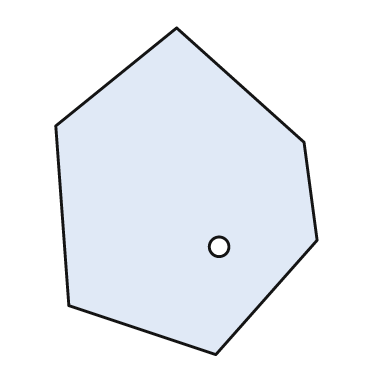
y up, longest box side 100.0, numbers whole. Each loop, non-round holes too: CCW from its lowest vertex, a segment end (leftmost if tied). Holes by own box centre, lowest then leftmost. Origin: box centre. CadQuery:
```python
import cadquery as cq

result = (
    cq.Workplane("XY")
    .moveTo(9.0, -50.0)
    .lineTo(40.0, -15.0)
    .lineTo(36.0, 15.0)
    .lineTo(-3.0, 50.0)
    .lineTo(-40.0, 20.0)
    .lineTo(-36.0, -35.0)
    .close()
    .moveTo(10.0, -17.0)
    .circle(3.0)
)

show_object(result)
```